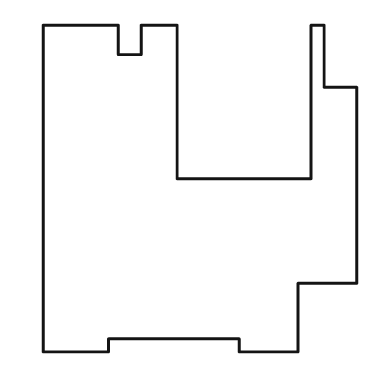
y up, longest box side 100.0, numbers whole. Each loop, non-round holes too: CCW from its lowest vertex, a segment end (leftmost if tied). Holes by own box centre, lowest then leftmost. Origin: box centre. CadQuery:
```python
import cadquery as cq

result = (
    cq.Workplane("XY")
    .moveTo(-48.0, -50.0)
    .lineTo(-28.0, -50.0)
    .lineTo(-28.0, -46.0)
    .lineTo(12.0, -46.0)
    .lineTo(12.0, -50.0)
    .lineTo(30.0, -50.0)
    .lineTo(30.0, -29.0)
    .lineTo(48.0, -29.0)
    .lineTo(48.0, 31.0)
    .lineTo(38.0, 31.0)
    .lineTo(38.0, 50.0)
    .lineTo(34.0, 50.0)
    .lineTo(34.0, 3.0)
    .lineTo(-7.0, 3.0)
    .lineTo(-7.0, 50.0)
    .lineTo(-18.0, 50.0)
    .lineTo(-18.0, 41.0)
    .lineTo(-25.0, 41.0)
    .lineTo(-25.0, 50.0)
    .lineTo(-48.0, 50.0)
    .close()
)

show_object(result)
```